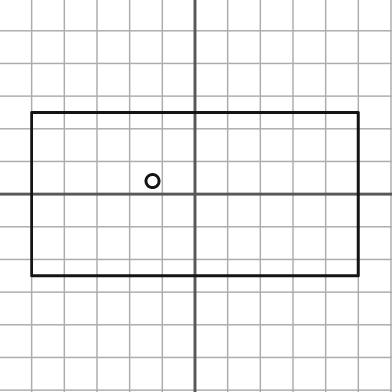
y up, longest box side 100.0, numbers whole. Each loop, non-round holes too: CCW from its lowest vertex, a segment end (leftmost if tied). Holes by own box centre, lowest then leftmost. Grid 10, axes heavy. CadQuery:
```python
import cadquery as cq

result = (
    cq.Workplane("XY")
    .moveTo(-50.0, -25.0)
    .lineTo(50.0, -25.0)
    .lineTo(50.0, 25.0)
    .lineTo(-50.0, 25.0)
    .close()
    .moveTo(-13.0, 4.0)
    .circle(2.0)
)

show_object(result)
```